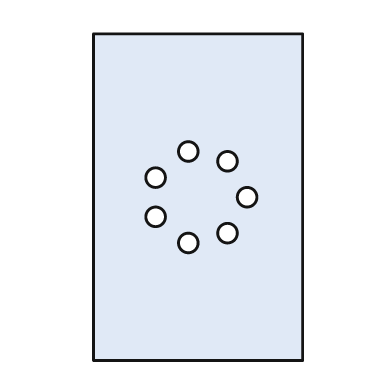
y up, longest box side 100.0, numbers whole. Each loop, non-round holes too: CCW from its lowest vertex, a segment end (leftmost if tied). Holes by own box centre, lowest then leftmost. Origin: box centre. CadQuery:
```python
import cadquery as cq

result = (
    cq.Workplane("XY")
    .moveTo(-32.0, -50.0)
    .lineTo(32.0, -50.0)
    .lineTo(32.0, 50.0)
    .lineTo(-32.0, 50.0)
    .close()
    .moveTo(-3.0, -14.0)
    .circle(3.0)
    .moveTo(9.0, -11.0)
    .circle(3.0)
    .moveTo(-13.0, -6.0)
    .circle(3.0)
    .moveTo(15.0, 0.0)
    .circle(3.0)
    .moveTo(-13.0, 6.0)
    .circle(3.0)
    .moveTo(9.0, 11.0)
    .circle(3.0)
    .moveTo(-3.0, 14.0)
    .circle(3.0)
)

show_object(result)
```